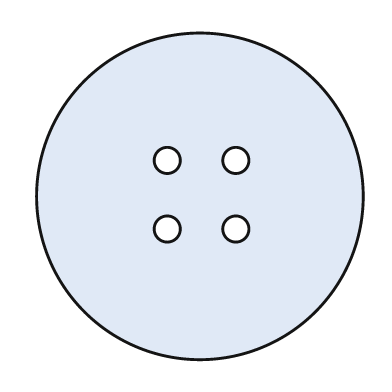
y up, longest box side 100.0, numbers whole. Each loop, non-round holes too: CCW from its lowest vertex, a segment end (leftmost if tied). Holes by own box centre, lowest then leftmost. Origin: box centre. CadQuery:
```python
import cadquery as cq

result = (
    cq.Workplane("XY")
    .moveTo(0.0, 0.0)
    .circle(50.0)
    .moveTo(-10.0, -10.0)
    .circle(4.0)
    .moveTo(11.0, -10.0)
    .circle(4.0)
    .moveTo(-10.0, 11.0)
    .circle(4.0)
    .moveTo(11.0, 11.0)
    .circle(4.0)
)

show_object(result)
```